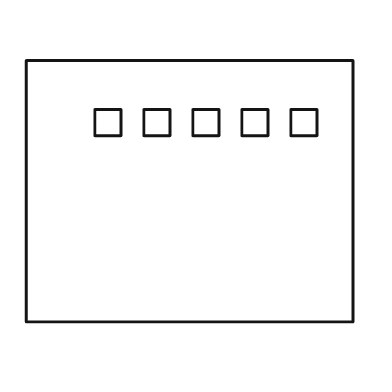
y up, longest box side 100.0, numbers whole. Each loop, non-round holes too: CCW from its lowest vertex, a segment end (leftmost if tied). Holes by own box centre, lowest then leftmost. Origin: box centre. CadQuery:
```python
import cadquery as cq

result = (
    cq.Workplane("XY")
    .moveTo(-50.0, -40.0)
    .lineTo(50.0, -40.0)
    .lineTo(50.0, 40.0)
    .lineTo(-50.0, 40.0)
    .close()
    .moveTo(-29.0, 17.0)
    .lineTo(-21.0, 17.0)
    .lineTo(-21.0, 25.0)
    .lineTo(-29.0, 25.0)
    .close()
    .moveTo(-14.0, 17.0)
    .lineTo(-6.0, 17.0)
    .lineTo(-6.0, 25.0)
    .lineTo(-14.0, 25.0)
    .close()
    .moveTo(1.0, 17.0)
    .lineTo(9.0, 17.0)
    .lineTo(9.0, 25.0)
    .lineTo(1.0, 25.0)
    .close()
    .moveTo(16.0, 17.0)
    .lineTo(24.0, 17.0)
    .lineTo(24.0, 25.0)
    .lineTo(16.0, 25.0)
    .close()
    .moveTo(31.0, 17.0)
    .lineTo(39.0, 17.0)
    .lineTo(39.0, 25.0)
    .lineTo(31.0, 25.0)
    .close()
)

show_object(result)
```